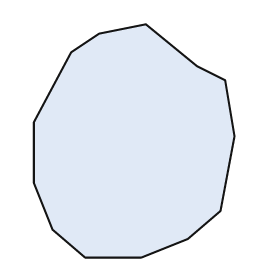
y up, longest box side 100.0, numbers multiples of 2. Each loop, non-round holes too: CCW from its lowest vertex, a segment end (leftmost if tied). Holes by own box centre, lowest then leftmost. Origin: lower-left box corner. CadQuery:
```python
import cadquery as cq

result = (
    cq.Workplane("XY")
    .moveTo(22.0, 0.0)
    .lineTo(46.0, 0.0)
    .lineTo(66.0, 8.0)
    .lineTo(80.0, 20.0)
    .lineTo(86.0, 52.0)
    .lineTo(82.0, 76.0)
    .lineTo(70.0, 82.0)
    .lineTo(48.0, 100.0)
    .lineTo(28.0, 96.0)
    .lineTo(16.0, 88.0)
    .lineTo(0.0, 58.0)
    .lineTo(0.0, 32.0)
    .lineTo(8.0, 12.0)
    .close()
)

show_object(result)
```